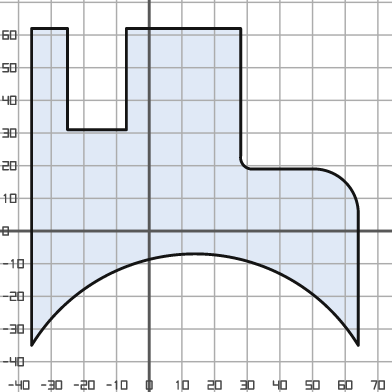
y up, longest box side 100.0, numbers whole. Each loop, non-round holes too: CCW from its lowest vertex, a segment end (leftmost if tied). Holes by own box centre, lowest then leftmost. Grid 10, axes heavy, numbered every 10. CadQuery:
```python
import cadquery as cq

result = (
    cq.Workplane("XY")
    .moveTo(-36.0, -35.0)
    .threePointArc((14.0, -7.0), (64.0, -35.0))
    .lineTo(64.0, 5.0)
    .threePointArc((60.0, 15.0), (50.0, 19.0))
    .lineTo(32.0, 19.0)
    .threePointArc((29.0, 20.0), (28.0, 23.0))
    .lineTo(28.0, 62.0)
    .lineTo(-7.0, 62.0)
    .lineTo(-7.0, 31.0)
    .lineTo(-25.0, 31.0)
    .lineTo(-25.0, 62.0)
    .lineTo(-36.0, 62.0)
    .close()
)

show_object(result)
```